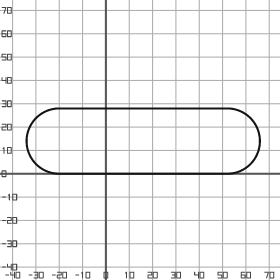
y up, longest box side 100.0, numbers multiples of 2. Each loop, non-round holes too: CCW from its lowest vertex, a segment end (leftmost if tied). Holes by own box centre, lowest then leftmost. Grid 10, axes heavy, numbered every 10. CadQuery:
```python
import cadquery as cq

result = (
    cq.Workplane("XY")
    .moveTo(-20.0, 0.0)
    .lineTo(52.0, 0.0)
    .threePointArc((66.0, 14.0), (52.0, 28.0))
    .lineTo(-20.0, 28.0)
    .threePointArc((-34.0, 14.0), (-20.0, 0.0))
    .close()
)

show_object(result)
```